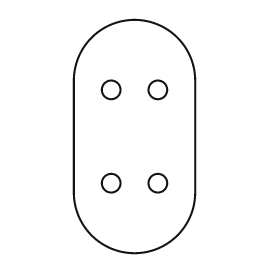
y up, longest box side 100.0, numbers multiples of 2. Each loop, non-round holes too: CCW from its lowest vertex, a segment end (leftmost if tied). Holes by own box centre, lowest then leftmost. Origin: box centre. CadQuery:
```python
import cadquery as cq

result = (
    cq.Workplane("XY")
    .moveTo(-26.0, -24.0)
    .threePointArc((0.0, -50.0), (26.0, -24.0))
    .lineTo(26.0, 24.0)
    .threePointArc((0.0, 50.0), (-26.0, 24.0))
    .close()
    .moveTo(-10.0, -20.0)
    .circle(4.0)
    .moveTo(10.0, -20.0)
    .circle(4.0)
    .moveTo(-10.0, 20.0)
    .circle(4.0)
    .moveTo(10.0, 20.0)
    .circle(4.0)
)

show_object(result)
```